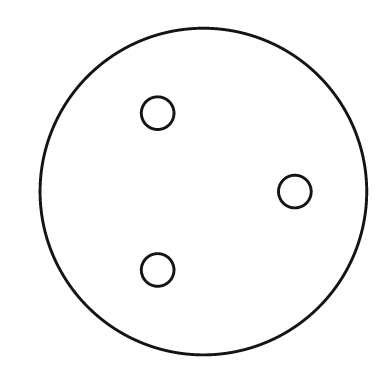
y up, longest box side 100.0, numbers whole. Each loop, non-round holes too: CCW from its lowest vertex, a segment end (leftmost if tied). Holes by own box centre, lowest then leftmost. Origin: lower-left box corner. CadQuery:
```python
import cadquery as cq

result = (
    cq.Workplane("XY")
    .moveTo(50.0, 50.0)
    .circle(50.0)
    .moveTo(36.0, 26.0)
    .circle(5.0)
    .moveTo(78.0, 50.0)
    .circle(5.0)
    .moveTo(36.0, 74.0)
    .circle(5.0)
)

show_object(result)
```